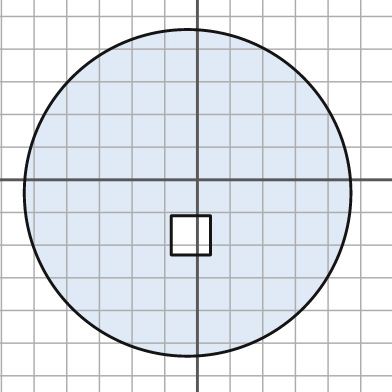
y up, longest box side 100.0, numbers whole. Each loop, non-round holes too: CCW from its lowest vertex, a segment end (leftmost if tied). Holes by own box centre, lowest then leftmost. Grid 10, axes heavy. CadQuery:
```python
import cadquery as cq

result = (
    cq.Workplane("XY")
    .moveTo(-3.0, -4.0)
    .circle(50.0)
    .moveTo(-8.0, -23.0)
    .lineTo(4.0, -23.0)
    .lineTo(4.0, -11.0)
    .lineTo(-8.0, -11.0)
    .close()
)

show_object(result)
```